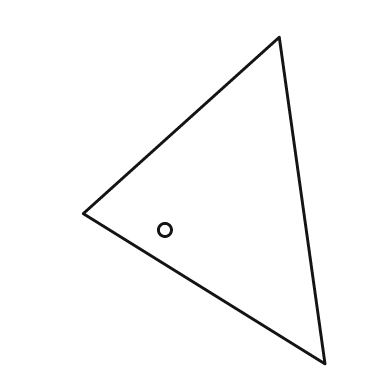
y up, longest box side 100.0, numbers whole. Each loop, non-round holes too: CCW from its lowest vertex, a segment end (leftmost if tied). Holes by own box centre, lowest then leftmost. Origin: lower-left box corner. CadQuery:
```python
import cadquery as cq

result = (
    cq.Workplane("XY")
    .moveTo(74.0, 0.0)
    .lineTo(60.0, 100.0)
    .lineTo(0.0, 46.0)
    .close()
    .moveTo(25.0, 41.0)
    .circle(2.0)
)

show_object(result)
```